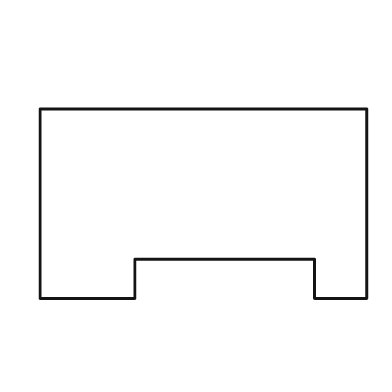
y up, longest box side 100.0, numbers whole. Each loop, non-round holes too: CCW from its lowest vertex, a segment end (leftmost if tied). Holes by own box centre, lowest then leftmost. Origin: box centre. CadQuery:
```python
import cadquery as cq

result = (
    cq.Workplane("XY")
    .moveTo(-50.0, -29.0)
    .lineTo(-21.0, -29.0)
    .lineTo(-21.0, -17.0)
    .lineTo(34.0, -17.0)
    .lineTo(34.0, -29.0)
    .lineTo(50.0, -29.0)
    .lineTo(50.0, 29.0)
    .lineTo(-50.0, 29.0)
    .close()
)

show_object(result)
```